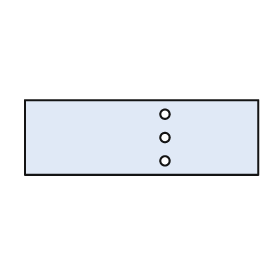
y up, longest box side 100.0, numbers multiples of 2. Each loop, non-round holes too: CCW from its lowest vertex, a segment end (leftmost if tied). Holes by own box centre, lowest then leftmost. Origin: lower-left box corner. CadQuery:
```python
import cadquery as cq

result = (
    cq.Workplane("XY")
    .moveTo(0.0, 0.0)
    .lineTo(100.0, 0.0)
    .lineTo(100.0, 32.0)
    .lineTo(0.0, 32.0)
    .close()
    .moveTo(60.0, 6.0)
    .circle(2.0)
    .moveTo(60.0, 16.0)
    .circle(2.0)
    .moveTo(60.0, 26.0)
    .circle(2.0)
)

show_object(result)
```